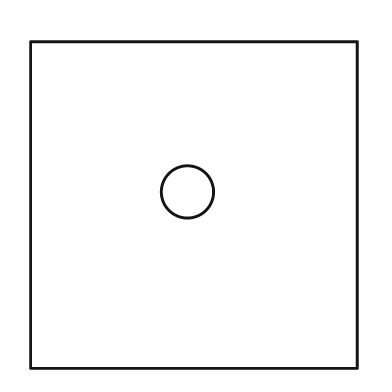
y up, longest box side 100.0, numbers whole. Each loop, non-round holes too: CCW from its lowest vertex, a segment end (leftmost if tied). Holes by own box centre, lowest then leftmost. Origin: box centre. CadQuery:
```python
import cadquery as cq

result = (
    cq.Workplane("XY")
    .moveTo(-50.0, -50.0)
    .lineTo(50.0, -50.0)
    .lineTo(50.0, 50.0)
    .lineTo(-50.0, 50.0)
    .close()
    .moveTo(-2.0, 4.0)
    .circle(8.0)
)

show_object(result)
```